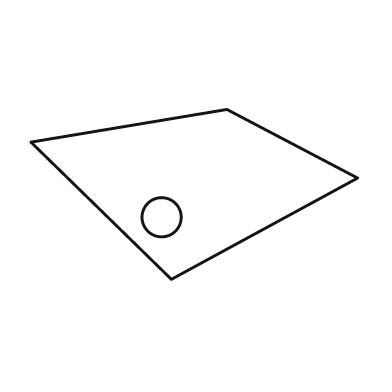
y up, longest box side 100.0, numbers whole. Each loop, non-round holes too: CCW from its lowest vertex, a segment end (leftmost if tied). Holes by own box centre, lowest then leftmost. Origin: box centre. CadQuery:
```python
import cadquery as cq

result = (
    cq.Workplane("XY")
    .moveTo(-7.0, -26.0)
    .lineTo(50.0, 5.0)
    .lineTo(10.0, 26.0)
    .lineTo(-50.0, 16.0)
    .close()
    .moveTo(-10.0, -7.0)
    .circle(6.0)
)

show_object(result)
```